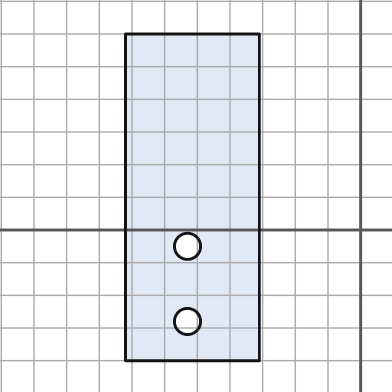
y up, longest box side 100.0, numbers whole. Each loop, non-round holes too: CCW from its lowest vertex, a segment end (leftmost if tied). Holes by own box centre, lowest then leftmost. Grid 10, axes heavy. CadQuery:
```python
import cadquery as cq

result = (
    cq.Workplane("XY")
    .moveTo(-72.0, -40.0)
    .lineTo(-31.0, -40.0)
    .lineTo(-31.0, 60.0)
    .lineTo(-72.0, 60.0)
    .close()
    .moveTo(-53.0, -28.0)
    .circle(4.0)
    .moveTo(-53.0, -5.0)
    .circle(4.0)
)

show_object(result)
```